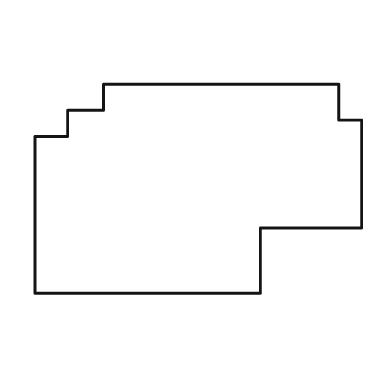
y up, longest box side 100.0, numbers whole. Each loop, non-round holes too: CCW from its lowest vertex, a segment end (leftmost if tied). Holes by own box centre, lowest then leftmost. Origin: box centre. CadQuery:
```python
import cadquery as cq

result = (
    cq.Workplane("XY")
    .moveTo(-50.0, -32.0)
    .lineTo(19.0, -32.0)
    .lineTo(19.0, -12.0)
    .lineTo(50.0, -12.0)
    .lineTo(50.0, 21.0)
    .lineTo(43.0, 21.0)
    .lineTo(43.0, 32.0)
    .lineTo(-29.0, 32.0)
    .lineTo(-29.0, 24.0)
    .lineTo(-40.0, 24.0)
    .lineTo(-40.0, 16.0)
    .lineTo(-50.0, 16.0)
    .close()
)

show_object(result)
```